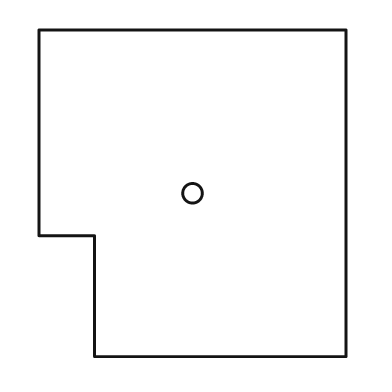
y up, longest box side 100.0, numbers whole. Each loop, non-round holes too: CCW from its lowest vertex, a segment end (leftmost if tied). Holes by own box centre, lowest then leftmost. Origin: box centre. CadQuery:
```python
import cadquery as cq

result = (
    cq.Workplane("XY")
    .moveTo(-30.0, -50.0)
    .lineTo(47.0, -50.0)
    .lineTo(47.0, 50.0)
    .lineTo(-47.0, 50.0)
    .lineTo(-47.0, -13.0)
    .lineTo(-30.0, -13.0)
    .close()
    .moveTo(0.0, 0.0)
    .circle(3.0)
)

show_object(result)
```